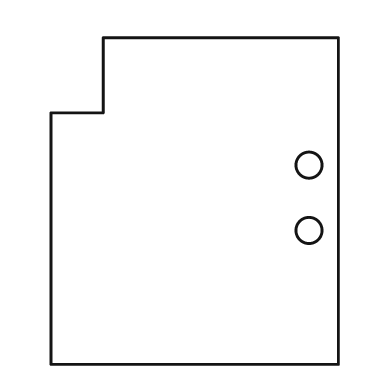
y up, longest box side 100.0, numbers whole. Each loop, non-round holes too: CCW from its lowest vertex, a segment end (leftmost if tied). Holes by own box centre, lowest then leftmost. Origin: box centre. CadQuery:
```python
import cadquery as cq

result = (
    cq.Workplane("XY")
    .moveTo(-44.0, -50.0)
    .lineTo(44.0, -50.0)
    .lineTo(44.0, 50.0)
    .lineTo(-28.0, 50.0)
    .lineTo(-28.0, 27.0)
    .lineTo(-44.0, 27.0)
    .close()
    .moveTo(35.0, -9.0)
    .circle(4.0)
    .moveTo(35.0, 11.0)
    .circle(4.0)
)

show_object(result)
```